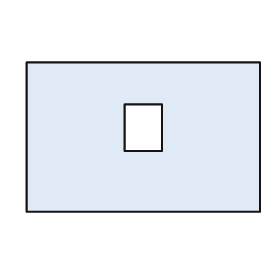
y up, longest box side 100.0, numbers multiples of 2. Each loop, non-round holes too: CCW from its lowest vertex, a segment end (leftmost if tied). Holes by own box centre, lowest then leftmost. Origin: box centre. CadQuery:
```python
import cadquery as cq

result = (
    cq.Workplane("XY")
    .moveTo(-50.0, -32.0)
    .lineTo(50.0, -32.0)
    .lineTo(50.0, 32.0)
    .lineTo(-50.0, 32.0)
    .close()
    .moveTo(-8.0, -6.0)
    .lineTo(8.0, -6.0)
    .lineTo(8.0, 14.0)
    .lineTo(-8.0, 14.0)
    .close()
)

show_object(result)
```